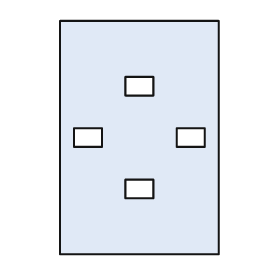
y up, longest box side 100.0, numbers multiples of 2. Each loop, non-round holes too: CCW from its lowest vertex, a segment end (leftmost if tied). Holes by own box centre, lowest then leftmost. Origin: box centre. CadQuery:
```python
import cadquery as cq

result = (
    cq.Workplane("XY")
    .moveTo(-34.0, -50.0)
    .lineTo(34.0, -50.0)
    .lineTo(34.0, 50.0)
    .lineTo(-34.0, 50.0)
    .close()
    .moveTo(-6.0, -26.0)
    .lineTo(6.0, -26.0)
    .lineTo(6.0, -18.0)
    .lineTo(-6.0, -18.0)
    .close()
    .moveTo(-28.0, -4.0)
    .lineTo(-16.0, -4.0)
    .lineTo(-16.0, 4.0)
    .lineTo(-28.0, 4.0)
    .close()
    .moveTo(16.0, -4.0)
    .lineTo(28.0, -4.0)
    .lineTo(28.0, 4.0)
    .lineTo(16.0, 4.0)
    .close()
    .moveTo(-6.0, 18.0)
    .lineTo(6.0, 18.0)
    .lineTo(6.0, 26.0)
    .lineTo(-6.0, 26.0)
    .close()
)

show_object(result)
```